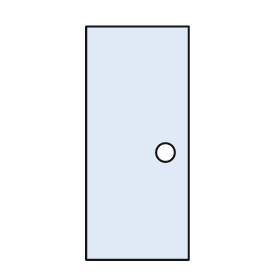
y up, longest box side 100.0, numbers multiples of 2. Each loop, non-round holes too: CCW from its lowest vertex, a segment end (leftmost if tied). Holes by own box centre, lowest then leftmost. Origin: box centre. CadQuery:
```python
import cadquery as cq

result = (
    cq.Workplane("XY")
    .moveTo(-22.0, -50.0)
    .lineTo(22.0, -50.0)
    .lineTo(22.0, 50.0)
    .lineTo(-22.0, 50.0)
    .close()
    .moveTo(12.0, -4.0)
    .circle(4.0)
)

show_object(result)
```